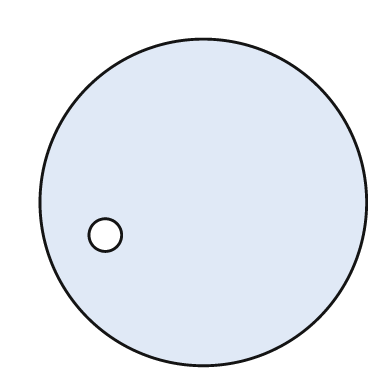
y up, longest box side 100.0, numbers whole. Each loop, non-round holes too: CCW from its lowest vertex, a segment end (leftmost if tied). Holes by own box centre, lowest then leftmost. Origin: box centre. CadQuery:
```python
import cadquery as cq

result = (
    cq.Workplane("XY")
    .moveTo(0.0, 0.0)
    .circle(50.0)
    .moveTo(-30.0, -10.0)
    .circle(5.0)
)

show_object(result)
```